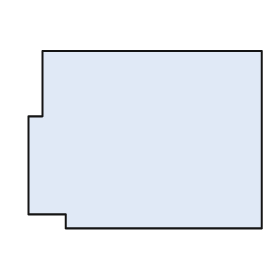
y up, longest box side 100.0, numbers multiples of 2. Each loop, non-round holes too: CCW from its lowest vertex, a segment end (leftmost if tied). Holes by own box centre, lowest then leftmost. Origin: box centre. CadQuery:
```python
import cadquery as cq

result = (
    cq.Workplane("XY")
    .moveTo(-34.0, -38.0)
    .lineTo(50.0, -38.0)
    .lineTo(50.0, 38.0)
    .lineTo(-44.0, 38.0)
    .lineTo(-44.0, 10.0)
    .lineTo(-50.0, 10.0)
    .lineTo(-50.0, -32.0)
    .lineTo(-34.0, -32.0)
    .close()
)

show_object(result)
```